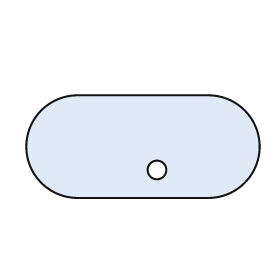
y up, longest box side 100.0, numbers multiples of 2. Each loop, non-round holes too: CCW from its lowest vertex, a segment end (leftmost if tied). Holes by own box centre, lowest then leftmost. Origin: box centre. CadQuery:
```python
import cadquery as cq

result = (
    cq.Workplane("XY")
    .moveTo(-28.0, -22.0)
    .lineTo(28.0, -22.0)
    .threePointArc((50.0, 0.0), (28.0, 22.0))
    .lineTo(-28.0, 22.0)
    .threePointArc((-50.0, 0.0), (-28.0, -22.0))
    .close()
    .moveTo(6.0, -10.0)
    .circle(4.0)
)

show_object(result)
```